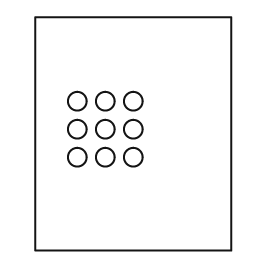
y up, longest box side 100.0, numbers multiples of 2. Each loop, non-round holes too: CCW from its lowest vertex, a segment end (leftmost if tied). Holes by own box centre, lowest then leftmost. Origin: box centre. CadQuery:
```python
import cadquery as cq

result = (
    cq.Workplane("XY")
    .moveTo(-42.0, -50.0)
    .lineTo(42.0, -50.0)
    .lineTo(42.0, 50.0)
    .lineTo(-42.0, 50.0)
    .close()
    .moveTo(-24.0, -10.0)
    .circle(4.0)
    .moveTo(-12.0, -10.0)
    .circle(4.0)
    .moveTo(0.0, -10.0)
    .circle(4.0)
    .moveTo(-24.0, 2.0)
    .circle(4.0)
    .moveTo(-12.0, 2.0)
    .circle(4.0)
    .moveTo(0.0, 2.0)
    .circle(4.0)
    .moveTo(-24.0, 14.0)
    .circle(4.0)
    .moveTo(-12.0, 14.0)
    .circle(4.0)
    .moveTo(0.0, 14.0)
    .circle(4.0)
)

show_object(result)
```